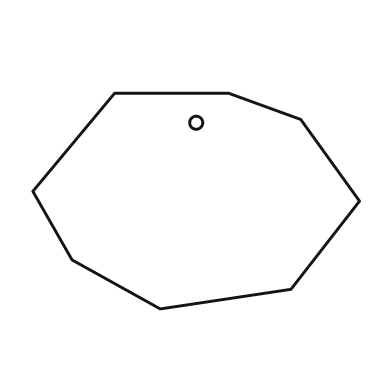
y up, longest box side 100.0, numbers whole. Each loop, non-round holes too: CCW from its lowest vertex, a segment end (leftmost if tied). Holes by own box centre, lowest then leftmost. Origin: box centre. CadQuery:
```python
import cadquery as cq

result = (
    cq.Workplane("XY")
    .moveTo(-11.0, -33.0)
    .lineTo(29.0, -27.0)
    .lineTo(50.0, 0.0)
    .lineTo(32.0, 25.0)
    .lineTo(10.0, 33.0)
    .lineTo(-25.0, 33.0)
    .lineTo(-50.0, 3.0)
    .lineTo(-38.0, -18.0)
    .close()
    .moveTo(0.0, 24.0)
    .circle(2.0)
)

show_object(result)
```